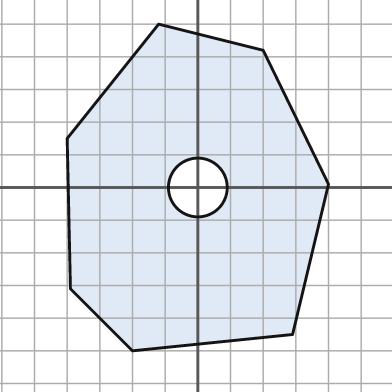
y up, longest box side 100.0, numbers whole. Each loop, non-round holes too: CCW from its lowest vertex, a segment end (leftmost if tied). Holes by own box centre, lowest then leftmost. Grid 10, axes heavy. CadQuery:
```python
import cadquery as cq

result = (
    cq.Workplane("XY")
    .moveTo(-20.0, -50.0)
    .lineTo(29.0, -45.0)
    .lineTo(40.0, 1.0)
    .lineTo(20.0, 42.0)
    .lineTo(-12.0, 50.0)
    .lineTo(-40.0, 15.0)
    .lineTo(-39.0, -31.0)
    .close()
    .moveTo(0.0, 0.0)
    .circle(9.0)
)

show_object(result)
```